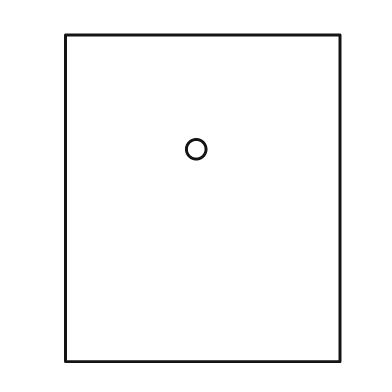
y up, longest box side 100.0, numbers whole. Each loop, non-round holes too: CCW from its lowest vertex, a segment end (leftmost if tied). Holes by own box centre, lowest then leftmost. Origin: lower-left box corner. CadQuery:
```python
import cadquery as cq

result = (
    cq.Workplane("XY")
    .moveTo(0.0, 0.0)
    .lineTo(84.0, 0.0)
    .lineTo(84.0, 100.0)
    .lineTo(0.0, 100.0)
    .close()
    .moveTo(40.0, 65.0)
    .circle(3.0)
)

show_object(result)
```